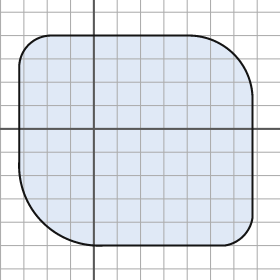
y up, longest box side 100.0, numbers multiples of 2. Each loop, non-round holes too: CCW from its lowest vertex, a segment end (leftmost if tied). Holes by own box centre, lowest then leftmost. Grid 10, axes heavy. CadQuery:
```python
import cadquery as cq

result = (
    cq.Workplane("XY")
    .moveTo(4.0, -50.0)
    .lineTo(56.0, -50.0)
    .threePointArc((64.0, -46.0), (68.0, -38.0))
    .lineTo(68.0, 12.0)
    .threePointArc((60.0, 32.0), (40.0, 40.0))
    .lineTo(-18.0, 40.0)
    .threePointArc((-28.0, 36.0), (-32.0, 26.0))
    .lineTo(-32.0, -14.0)
    .threePointArc((-22.0, -40.0), (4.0, -50.0))
    .close()
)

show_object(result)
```